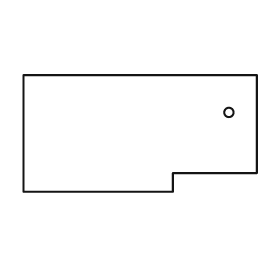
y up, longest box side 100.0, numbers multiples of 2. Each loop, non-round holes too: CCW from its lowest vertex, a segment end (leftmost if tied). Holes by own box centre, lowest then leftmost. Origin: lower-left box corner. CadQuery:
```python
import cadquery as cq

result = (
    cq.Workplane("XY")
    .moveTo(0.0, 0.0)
    .lineTo(64.0, 0.0)
    .lineTo(64.0, 8.0)
    .lineTo(100.0, 8.0)
    .lineTo(100.0, 50.0)
    .lineTo(0.0, 50.0)
    .close()
    .moveTo(88.0, 34.0)
    .circle(2.0)
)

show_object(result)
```